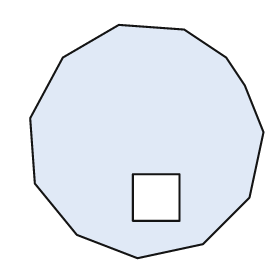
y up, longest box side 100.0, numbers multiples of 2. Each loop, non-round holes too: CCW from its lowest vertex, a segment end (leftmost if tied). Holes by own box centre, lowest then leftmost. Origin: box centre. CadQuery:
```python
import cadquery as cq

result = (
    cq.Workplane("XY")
    .moveTo(-4.0, -50.0)
    .lineTo(24.0, -44.0)
    .lineTo(44.0, -24.0)
    .lineTo(50.0, 4.0)
    .lineTo(42.0, 24.0)
    .lineTo(34.0, 36.0)
    .lineTo(16.0, 48.0)
    .lineTo(-12.0, 50.0)
    .lineTo(-36.0, 36.0)
    .lineTo(-50.0, 10.0)
    .lineTo(-48.0, -18.0)
    .lineTo(-30.0, -40.0)
    .close()
    .moveTo(-6.0, -34.0)
    .lineTo(14.0, -34.0)
    .lineTo(14.0, -14.0)
    .lineTo(-6.0, -14.0)
    .close()
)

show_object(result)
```